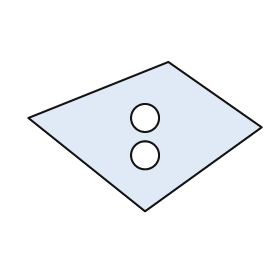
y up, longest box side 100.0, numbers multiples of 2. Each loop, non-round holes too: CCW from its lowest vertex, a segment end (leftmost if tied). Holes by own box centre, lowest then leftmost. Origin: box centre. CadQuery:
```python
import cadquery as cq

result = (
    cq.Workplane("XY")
    .moveTo(0.0, -32.0)
    .lineTo(50.0, 4.0)
    .lineTo(10.0, 32.0)
    .lineTo(-50.0, 8.0)
    .close()
    .moveTo(0.0, -8.0)
    .circle(6.0)
    .moveTo(0.0, 8.0)
    .circle(6.0)
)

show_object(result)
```